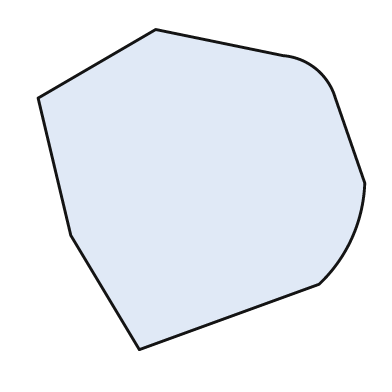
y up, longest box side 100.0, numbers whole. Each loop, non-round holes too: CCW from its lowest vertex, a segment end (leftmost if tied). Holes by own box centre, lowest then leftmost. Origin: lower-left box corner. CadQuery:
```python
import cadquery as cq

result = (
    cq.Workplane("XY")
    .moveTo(31.0, 0.0)
    .lineTo(86.0, 20.0)
    .threePointArc((96.0, 34.0), (100.0, 51.0))
    .lineTo(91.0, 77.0)
    .threePointArc((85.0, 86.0), (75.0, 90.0))
    .lineTo(36.0, 98.0)
    .lineTo(0.0, 77.0)
    .lineTo(10.0, 35.0)
    .close()
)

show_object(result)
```